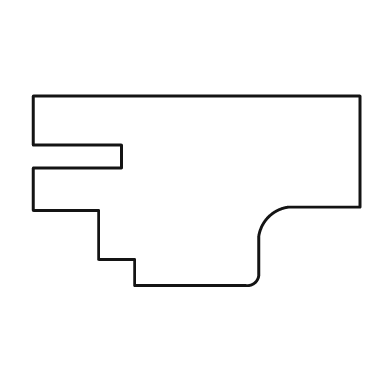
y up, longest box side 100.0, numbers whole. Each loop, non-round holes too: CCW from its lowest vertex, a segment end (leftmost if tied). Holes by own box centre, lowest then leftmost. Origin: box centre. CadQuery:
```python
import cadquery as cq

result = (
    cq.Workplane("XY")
    .moveTo(-19.0, -29.0)
    .lineTo(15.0, -29.0)
    .threePointArc((18.0, -28.0), (19.0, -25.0))
    .lineTo(19.0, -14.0)
    .threePointArc((22.0, -8.0), (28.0, -5.0))
    .lineTo(50.0, -5.0)
    .lineTo(50.0, 29.0)
    .lineTo(-50.0, 29.0)
    .lineTo(-50.0, 14.0)
    .lineTo(-23.0, 14.0)
    .lineTo(-23.0, 7.0)
    .lineTo(-50.0, 7.0)
    .lineTo(-50.0, -6.0)
    .lineTo(-30.0, -6.0)
    .lineTo(-30.0, -21.0)
    .lineTo(-19.0, -21.0)
    .close()
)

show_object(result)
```